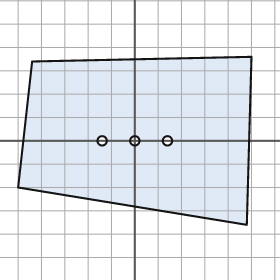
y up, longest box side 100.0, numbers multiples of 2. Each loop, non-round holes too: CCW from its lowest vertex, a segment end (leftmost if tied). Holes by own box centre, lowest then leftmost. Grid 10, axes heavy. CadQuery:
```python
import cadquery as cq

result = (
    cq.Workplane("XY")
    .moveTo(48.0, -36.0)
    .lineTo(50.0, 36.0)
    .lineTo(-44.0, 34.0)
    .lineTo(-50.0, -20.0)
    .close()
    .moveTo(-14.0, 0.0)
    .circle(2.0)
    .moveTo(0.0, 0.0)
    .circle(2.0)
    .moveTo(14.0, 0.0)
    .circle(2.0)
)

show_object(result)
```